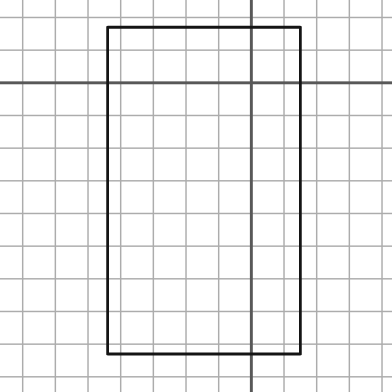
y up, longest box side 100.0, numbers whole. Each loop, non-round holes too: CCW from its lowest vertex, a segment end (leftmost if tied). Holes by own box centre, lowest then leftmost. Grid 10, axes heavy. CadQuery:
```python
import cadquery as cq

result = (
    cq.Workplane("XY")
    .moveTo(-44.0, -83.0)
    .lineTo(15.0, -83.0)
    .lineTo(15.0, 17.0)
    .lineTo(-44.0, 17.0)
    .close()
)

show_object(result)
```